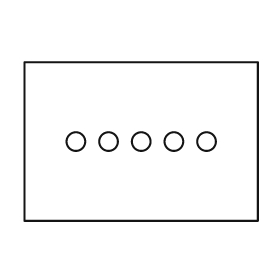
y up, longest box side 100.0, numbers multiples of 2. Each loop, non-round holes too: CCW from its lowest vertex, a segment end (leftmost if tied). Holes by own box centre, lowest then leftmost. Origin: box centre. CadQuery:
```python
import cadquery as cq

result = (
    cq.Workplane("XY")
    .moveTo(-50.0, -34.0)
    .lineTo(50.0, -34.0)
    .lineTo(50.0, 34.0)
    .lineTo(-50.0, 34.0)
    .close()
    .moveTo(-28.0, 0.0)
    .circle(4.0)
    .moveTo(-14.0, 0.0)
    .circle(4.0)
    .moveTo(0.0, 0.0)
    .circle(4.0)
    .moveTo(14.0, 0.0)
    .circle(4.0)
    .moveTo(28.0, 0.0)
    .circle(4.0)
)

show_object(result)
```